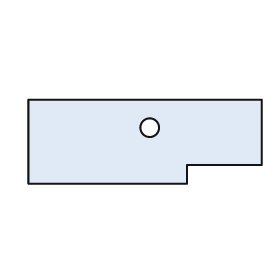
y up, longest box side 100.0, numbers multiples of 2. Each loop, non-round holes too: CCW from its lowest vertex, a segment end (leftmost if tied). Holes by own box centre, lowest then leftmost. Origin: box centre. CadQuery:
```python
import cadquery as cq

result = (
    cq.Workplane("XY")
    .moveTo(-50.0, -18.0)
    .lineTo(18.0, -18.0)
    .lineTo(18.0, -10.0)
    .lineTo(50.0, -10.0)
    .lineTo(50.0, 18.0)
    .lineTo(-50.0, 18.0)
    .close()
    .moveTo(2.0, 6.0)
    .circle(4.0)
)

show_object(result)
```